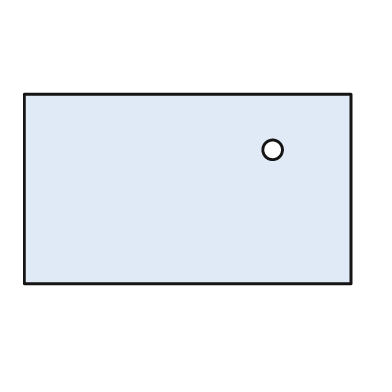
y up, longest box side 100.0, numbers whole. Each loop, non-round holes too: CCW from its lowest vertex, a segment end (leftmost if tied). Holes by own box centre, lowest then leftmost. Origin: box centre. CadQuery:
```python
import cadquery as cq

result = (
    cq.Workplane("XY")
    .moveTo(-50.0, -29.0)
    .lineTo(50.0, -29.0)
    .lineTo(50.0, 29.0)
    .lineTo(-50.0, 29.0)
    .close()
    .moveTo(26.0, 12.0)
    .circle(3.0)
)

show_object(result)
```